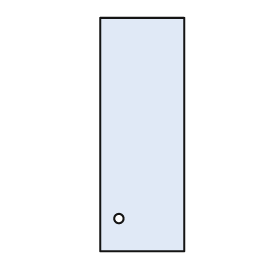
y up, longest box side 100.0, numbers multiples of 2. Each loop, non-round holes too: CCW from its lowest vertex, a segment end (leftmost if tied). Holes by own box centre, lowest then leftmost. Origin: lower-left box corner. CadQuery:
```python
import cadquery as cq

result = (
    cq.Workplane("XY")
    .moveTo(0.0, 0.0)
    .lineTo(36.0, 0.0)
    .lineTo(36.0, 100.0)
    .lineTo(0.0, 100.0)
    .close()
    .moveTo(8.0, 14.0)
    .circle(2.0)
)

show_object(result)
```